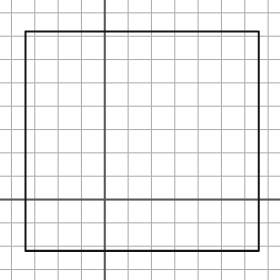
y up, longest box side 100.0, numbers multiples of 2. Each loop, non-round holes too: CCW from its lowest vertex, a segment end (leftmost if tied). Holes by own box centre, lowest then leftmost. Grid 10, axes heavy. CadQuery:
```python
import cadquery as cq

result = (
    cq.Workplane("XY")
    .moveTo(-34.0, -22.0)
    .lineTo(66.0, -22.0)
    .lineTo(66.0, 72.0)
    .lineTo(-34.0, 72.0)
    .close()
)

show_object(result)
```